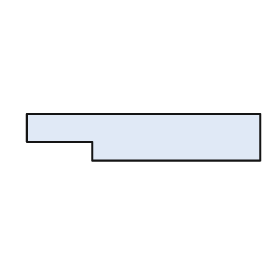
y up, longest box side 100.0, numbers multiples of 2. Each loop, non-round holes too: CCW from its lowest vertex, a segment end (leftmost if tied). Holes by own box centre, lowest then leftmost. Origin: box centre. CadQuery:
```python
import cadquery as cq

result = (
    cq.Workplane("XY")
    .moveTo(-22.0, -10.0)
    .lineTo(50.0, -10.0)
    .lineTo(50.0, 10.0)
    .lineTo(-50.0, 10.0)
    .lineTo(-50.0, -2.0)
    .lineTo(-22.0, -2.0)
    .close()
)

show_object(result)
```